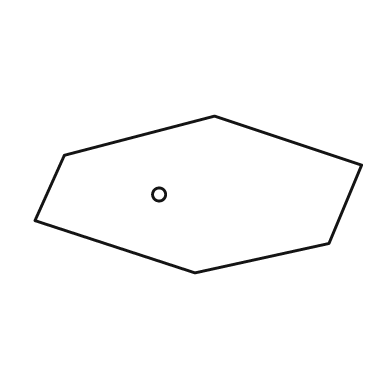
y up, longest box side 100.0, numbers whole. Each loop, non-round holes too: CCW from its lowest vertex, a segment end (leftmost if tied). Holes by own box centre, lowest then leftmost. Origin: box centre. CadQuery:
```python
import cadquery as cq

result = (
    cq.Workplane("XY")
    .moveTo(-1.0, -24.0)
    .lineTo(40.0, -15.0)
    .lineTo(50.0, 9.0)
    .lineTo(5.0, 24.0)
    .lineTo(-41.0, 12.0)
    .lineTo(-50.0, -8.0)
    .close()
    .moveTo(-12.0, 0.0)
    .circle(2.0)
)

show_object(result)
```